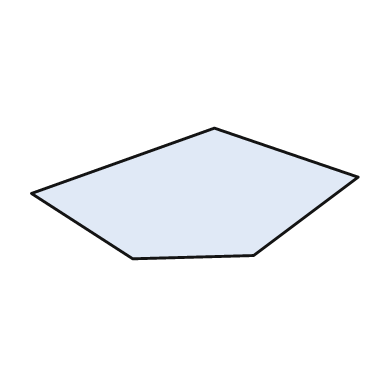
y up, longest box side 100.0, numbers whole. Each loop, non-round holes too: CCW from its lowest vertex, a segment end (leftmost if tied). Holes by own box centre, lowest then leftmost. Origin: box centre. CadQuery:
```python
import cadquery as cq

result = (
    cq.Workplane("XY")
    .moveTo(-19.0, -20.0)
    .lineTo(18.0, -19.0)
    .lineTo(50.0, 5.0)
    .lineTo(6.0, 20.0)
    .lineTo(-50.0, 0.0)
    .close()
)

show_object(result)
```